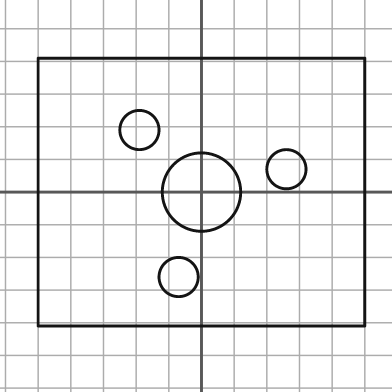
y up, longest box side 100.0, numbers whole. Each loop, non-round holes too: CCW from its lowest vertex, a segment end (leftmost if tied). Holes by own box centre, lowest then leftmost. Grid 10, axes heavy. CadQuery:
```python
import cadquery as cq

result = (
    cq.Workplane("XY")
    .moveTo(-50.0, -41.0)
    .lineTo(50.0, -41.0)
    .lineTo(50.0, 41.0)
    .lineTo(-50.0, 41.0)
    .close()
    .moveTo(-7.0, -26.0)
    .circle(6.0)
    .moveTo(0.0, 0.0)
    .circle(12.0)
    .moveTo(26.0, 7.0)
    .circle(6.0)
    .moveTo(-19.0, 19.0)
    .circle(6.0)
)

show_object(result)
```